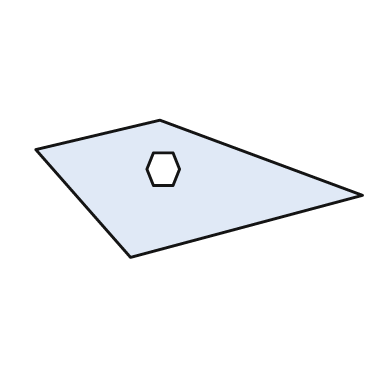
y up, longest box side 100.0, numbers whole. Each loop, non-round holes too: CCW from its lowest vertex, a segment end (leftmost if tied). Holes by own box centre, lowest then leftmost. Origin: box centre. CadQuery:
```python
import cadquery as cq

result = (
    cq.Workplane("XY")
    .moveTo(-21.0, -21.0)
    .lineTo(50.0, -2.0)
    .lineTo(-12.0, 21.0)
    .lineTo(-50.0, 12.0)
    .close()
    .moveTo(-14.0, 1.0)
    .lineTo(-8.0, 1.0)
    .lineTo(-6.0, 6.0)
    .lineTo(-8.0, 11.0)
    .lineTo(-14.0, 11.0)
    .lineTo(-16.0, 6.0)
    .close()
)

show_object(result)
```